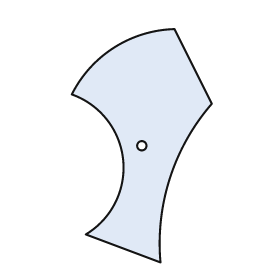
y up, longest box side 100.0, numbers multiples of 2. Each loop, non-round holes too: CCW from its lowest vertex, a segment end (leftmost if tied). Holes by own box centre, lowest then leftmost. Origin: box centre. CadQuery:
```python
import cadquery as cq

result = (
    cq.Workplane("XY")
    .moveTo(8.0, -50.0)
    .threePointArc((12.0, -14.0), (30.0, 18.0))
    .lineTo(14.0, 50.0)
    .threePointArc((-12.0, 42.0), (-30.0, 22.0))
    .threePointArc((-8.0, -6.0), (-24.0, -38.0))
    .close()
    .moveTo(0.0, 0.0)
    .circle(2.0)
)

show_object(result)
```